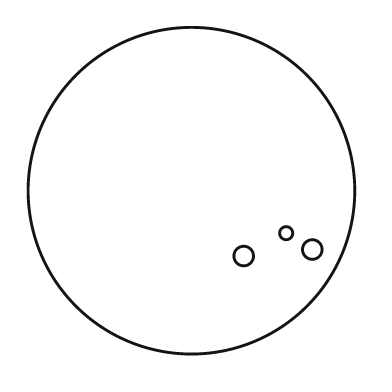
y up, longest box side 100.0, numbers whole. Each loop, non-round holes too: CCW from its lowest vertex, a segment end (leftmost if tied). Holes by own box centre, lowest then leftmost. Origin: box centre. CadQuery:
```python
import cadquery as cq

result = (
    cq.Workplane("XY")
    .moveTo(0.0, 0.0)
    .circle(50.0)
    .moveTo(16.0, -20.0)
    .circle(3.0)
    .moveTo(37.0, -18.0)
    .circle(3.0)
    .moveTo(29.0, -13.0)
    .circle(2.0)
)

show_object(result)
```